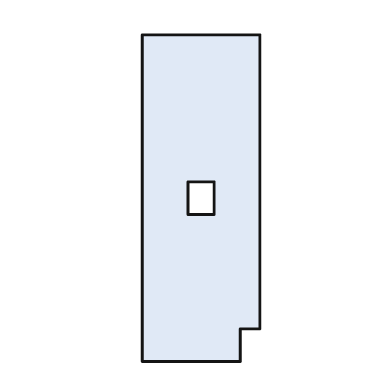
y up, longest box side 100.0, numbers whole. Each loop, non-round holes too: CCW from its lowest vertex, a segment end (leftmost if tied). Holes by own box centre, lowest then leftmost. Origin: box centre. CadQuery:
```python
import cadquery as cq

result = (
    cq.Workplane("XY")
    .moveTo(-18.0, -50.0)
    .lineTo(12.0, -50.0)
    .lineTo(12.0, -40.0)
    .lineTo(18.0, -40.0)
    .lineTo(18.0, 50.0)
    .lineTo(-18.0, 50.0)
    .close()
    .moveTo(-4.0, -5.0)
    .lineTo(4.0, -5.0)
    .lineTo(4.0, 5.0)
    .lineTo(-4.0, 5.0)
    .close()
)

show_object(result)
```